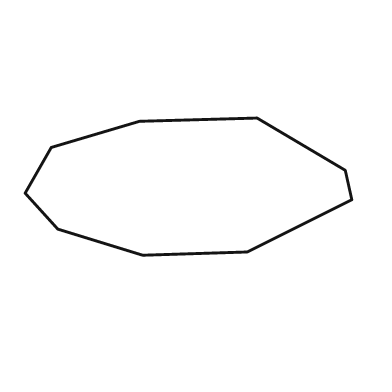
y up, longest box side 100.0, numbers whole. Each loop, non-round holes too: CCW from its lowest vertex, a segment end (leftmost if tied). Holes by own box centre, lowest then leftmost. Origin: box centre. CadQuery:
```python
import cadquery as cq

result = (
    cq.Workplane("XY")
    .moveTo(-14.0, -21.0)
    .lineTo(18.0, -20.0)
    .lineTo(50.0, -4.0)
    .lineTo(48.0, 5.0)
    .lineTo(21.0, 21.0)
    .lineTo(-15.0, 20.0)
    .lineTo(-42.0, 12.0)
    .lineTo(-50.0, -2.0)
    .lineTo(-40.0, -13.0)
    .close()
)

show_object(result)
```